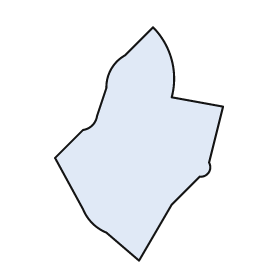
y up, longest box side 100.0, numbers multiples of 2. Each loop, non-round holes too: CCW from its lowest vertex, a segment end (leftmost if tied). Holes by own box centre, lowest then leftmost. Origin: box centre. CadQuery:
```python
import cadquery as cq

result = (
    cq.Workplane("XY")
    .moveTo(0.0, -50.0)
    .lineTo(14.0, -26.0)
    .lineTo(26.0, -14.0)
    .threePointArc((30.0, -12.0), (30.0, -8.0))
    .lineTo(36.0, 16.0)
    .lineTo(14.0, 20.0)
    .threePointArc((14.0, 36.0), (6.0, 50.0))
    .lineTo(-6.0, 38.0)
    .threePointArc((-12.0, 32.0), (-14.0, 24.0))
    .lineTo(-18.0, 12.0)
    .threePointArc((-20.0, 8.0), (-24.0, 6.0))
    .lineTo(-36.0, -6.0)
    .lineTo(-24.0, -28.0)
    .threePointArc((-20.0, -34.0), (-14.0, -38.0))
    .close()
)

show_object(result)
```